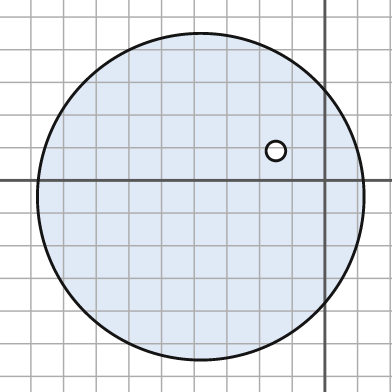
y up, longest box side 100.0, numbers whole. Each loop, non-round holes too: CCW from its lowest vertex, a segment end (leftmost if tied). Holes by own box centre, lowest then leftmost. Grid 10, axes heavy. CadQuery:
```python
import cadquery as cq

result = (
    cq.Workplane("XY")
    .moveTo(-38.0, -5.0)
    .circle(50.0)
    .moveTo(-15.0, 9.0)
    .circle(3.0)
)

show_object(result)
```